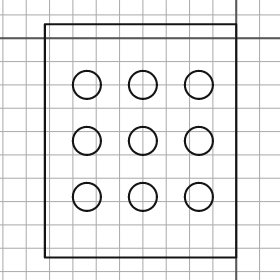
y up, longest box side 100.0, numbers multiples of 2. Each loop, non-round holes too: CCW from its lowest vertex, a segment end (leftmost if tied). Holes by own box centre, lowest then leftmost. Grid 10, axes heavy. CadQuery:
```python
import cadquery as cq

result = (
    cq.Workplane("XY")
    .moveTo(-82.0, -94.0)
    .lineTo(0.0, -94.0)
    .lineTo(0.0, 6.0)
    .lineTo(-82.0, 6.0)
    .close()
    .moveTo(-64.0, -68.0)
    .circle(6.0)
    .moveTo(-40.0, -68.0)
    .circle(6.0)
    .moveTo(-16.0, -68.0)
    .circle(6.0)
    .moveTo(-64.0, -44.0)
    .circle(6.0)
    .moveTo(-40.0, -44.0)
    .circle(6.0)
    .moveTo(-16.0, -44.0)
    .circle(6.0)
    .moveTo(-64.0, -20.0)
    .circle(6.0)
    .moveTo(-40.0, -20.0)
    .circle(6.0)
    .moveTo(-16.0, -20.0)
    .circle(6.0)
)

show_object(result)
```